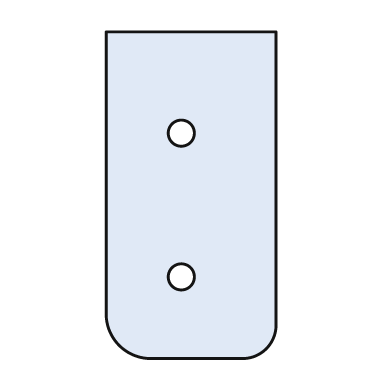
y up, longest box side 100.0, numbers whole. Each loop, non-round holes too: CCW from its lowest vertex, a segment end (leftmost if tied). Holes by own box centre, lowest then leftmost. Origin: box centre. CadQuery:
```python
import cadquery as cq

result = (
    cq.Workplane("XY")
    .moveTo(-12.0, -50.0)
    .lineTo(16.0, -50.0)
    .threePointArc((23.0, -47.0), (26.0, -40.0))
    .lineTo(26.0, 50.0)
    .lineTo(-26.0, 50.0)
    .lineTo(-26.0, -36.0)
    .threePointArc((-22.0, -46.0), (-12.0, -50.0))
    .close()
    .moveTo(-3.0, -25.0)
    .circle(4.0)
    .moveTo(-3.0, 19.0)
    .circle(4.0)
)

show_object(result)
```